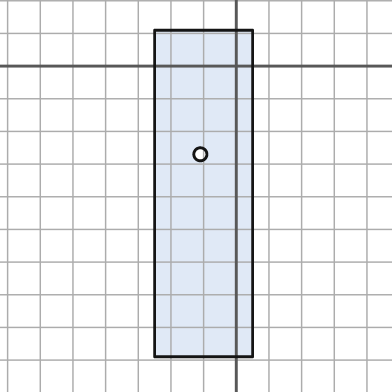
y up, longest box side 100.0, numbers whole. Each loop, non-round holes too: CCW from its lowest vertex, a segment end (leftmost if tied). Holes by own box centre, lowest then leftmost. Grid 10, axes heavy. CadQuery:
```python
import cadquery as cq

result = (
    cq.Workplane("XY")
    .moveTo(-25.0, -89.0)
    .lineTo(5.0, -89.0)
    .lineTo(5.0, 11.0)
    .lineTo(-25.0, 11.0)
    .close()
    .moveTo(-11.0, -27.0)
    .circle(2.0)
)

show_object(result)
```